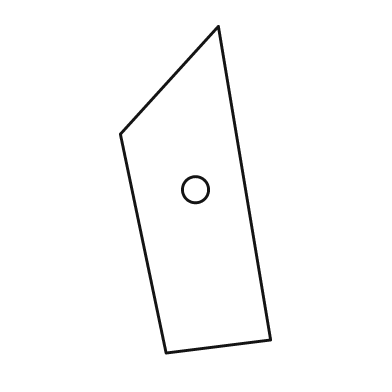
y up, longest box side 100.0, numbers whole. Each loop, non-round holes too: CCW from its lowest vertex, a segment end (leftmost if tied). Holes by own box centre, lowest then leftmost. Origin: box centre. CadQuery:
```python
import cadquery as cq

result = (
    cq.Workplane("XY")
    .moveTo(-9.0, -50.0)
    .lineTo(23.0, -46.0)
    .lineTo(7.0, 50.0)
    .lineTo(-23.0, 17.0)
    .close()
    .moveTo(0.0, 0.0)
    .circle(4.0)
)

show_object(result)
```